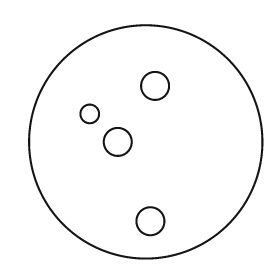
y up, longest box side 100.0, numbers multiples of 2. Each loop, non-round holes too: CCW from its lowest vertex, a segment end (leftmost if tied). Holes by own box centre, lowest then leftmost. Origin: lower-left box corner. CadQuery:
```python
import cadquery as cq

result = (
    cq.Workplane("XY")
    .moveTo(50.0, 50.0)
    .circle(50.0)
    .moveTo(52.0, 16.0)
    .circle(6.0)
    .moveTo(38.0, 50.0)
    .circle(6.0)
    .moveTo(26.0, 62.0)
    .circle(4.0)
    .moveTo(54.0, 74.0)
    .circle(6.0)
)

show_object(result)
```